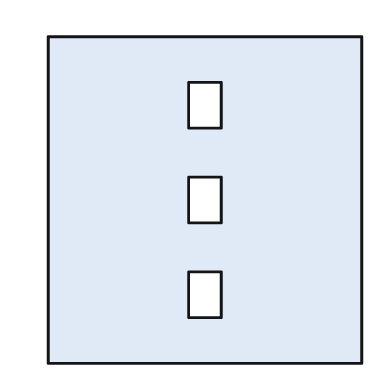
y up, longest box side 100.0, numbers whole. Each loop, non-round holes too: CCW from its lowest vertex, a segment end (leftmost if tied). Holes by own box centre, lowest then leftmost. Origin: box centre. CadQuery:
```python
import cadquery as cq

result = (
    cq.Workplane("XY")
    .moveTo(-48.0, -50.0)
    .lineTo(48.0, -50.0)
    .lineTo(48.0, 50.0)
    .lineTo(-48.0, 50.0)
    .close()
    .moveTo(-5.0, -36.0)
    .lineTo(5.0, -36.0)
    .lineTo(5.0, -22.0)
    .lineTo(-5.0, -22.0)
    .close()
    .moveTo(-5.0, -7.0)
    .lineTo(5.0, -7.0)
    .lineTo(5.0, 7.0)
    .lineTo(-5.0, 7.0)
    .close()
    .moveTo(-5.0, 22.0)
    .lineTo(5.0, 22.0)
    .lineTo(5.0, 36.0)
    .lineTo(-5.0, 36.0)
    .close()
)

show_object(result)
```